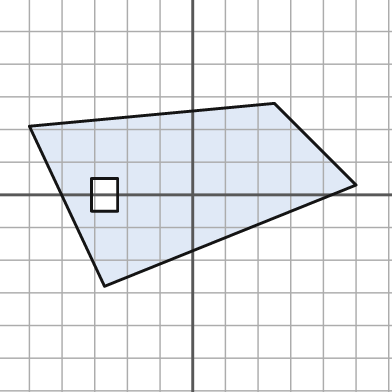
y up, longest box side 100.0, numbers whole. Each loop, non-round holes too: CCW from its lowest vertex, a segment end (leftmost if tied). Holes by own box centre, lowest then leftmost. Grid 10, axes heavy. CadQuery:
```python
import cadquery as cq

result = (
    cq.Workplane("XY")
    .moveTo(-27.0, -28.0)
    .lineTo(50.0, 3.0)
    .lineTo(25.0, 28.0)
    .lineTo(-50.0, 21.0)
    .close()
    .moveTo(-31.0, -5.0)
    .lineTo(-23.0, -5.0)
    .lineTo(-23.0, 5.0)
    .lineTo(-31.0, 5.0)
    .close()
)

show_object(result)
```